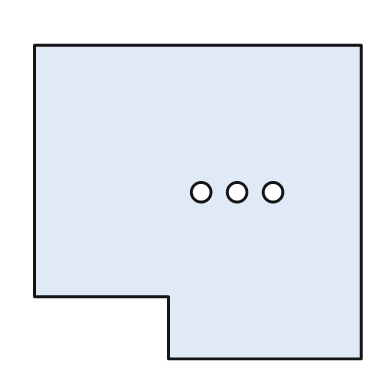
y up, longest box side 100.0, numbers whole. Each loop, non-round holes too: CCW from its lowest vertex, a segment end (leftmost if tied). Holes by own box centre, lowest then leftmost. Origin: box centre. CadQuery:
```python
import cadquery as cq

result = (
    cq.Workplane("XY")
    .moveTo(-9.0, -48.0)
    .lineTo(50.0, -48.0)
    .lineTo(50.0, 48.0)
    .lineTo(-50.0, 48.0)
    .lineTo(-50.0, -29.0)
    .lineTo(-9.0, -29.0)
    .close()
    .moveTo(1.0, 3.0)
    .circle(3.0)
    .moveTo(12.0, 3.0)
    .circle(3.0)
    .moveTo(23.0, 3.0)
    .circle(3.0)
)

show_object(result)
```